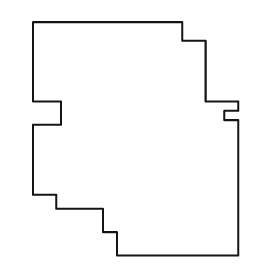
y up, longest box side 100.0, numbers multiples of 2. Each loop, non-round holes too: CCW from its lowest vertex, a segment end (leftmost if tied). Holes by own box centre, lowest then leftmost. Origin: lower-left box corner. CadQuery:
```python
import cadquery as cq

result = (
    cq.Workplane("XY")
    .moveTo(36.0, 0.0)
    .lineTo(88.0, 0.0)
    .lineTo(88.0, 58.0)
    .lineTo(82.0, 58.0)
    .lineTo(82.0, 62.0)
    .lineTo(88.0, 62.0)
    .lineTo(88.0, 66.0)
    .lineTo(74.0, 66.0)
    .lineTo(74.0, 92.0)
    .lineTo(64.0, 92.0)
    .lineTo(64.0, 100.0)
    .lineTo(0.0, 100.0)
    .lineTo(0.0, 66.0)
    .lineTo(12.0, 66.0)
    .lineTo(12.0, 56.0)
    .lineTo(0.0, 56.0)
    .lineTo(0.0, 26.0)
    .lineTo(10.0, 26.0)
    .lineTo(10.0, 20.0)
    .lineTo(30.0, 20.0)
    .lineTo(30.0, 10.0)
    .lineTo(36.0, 10.0)
    .close()
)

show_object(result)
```